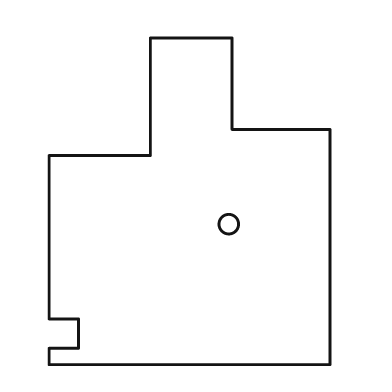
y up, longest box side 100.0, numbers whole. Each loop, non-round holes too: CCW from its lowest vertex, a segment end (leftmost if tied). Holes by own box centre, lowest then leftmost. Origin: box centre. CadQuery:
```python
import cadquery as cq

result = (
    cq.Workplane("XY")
    .moveTo(-43.0, -50.0)
    .lineTo(43.0, -50.0)
    .lineTo(43.0, 22.0)
    .lineTo(13.0, 22.0)
    .lineTo(13.0, 50.0)
    .lineTo(-12.0, 50.0)
    .lineTo(-12.0, 14.0)
    .lineTo(-43.0, 14.0)
    .lineTo(-43.0, -36.0)
    .lineTo(-34.0, -36.0)
    .lineTo(-34.0, -45.0)
    .lineTo(-43.0, -45.0)
    .close()
    .moveTo(12.0, -7.0)
    .circle(3.0)
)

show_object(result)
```